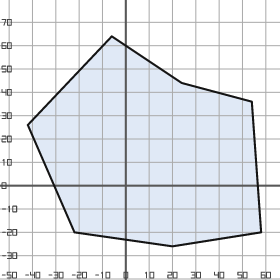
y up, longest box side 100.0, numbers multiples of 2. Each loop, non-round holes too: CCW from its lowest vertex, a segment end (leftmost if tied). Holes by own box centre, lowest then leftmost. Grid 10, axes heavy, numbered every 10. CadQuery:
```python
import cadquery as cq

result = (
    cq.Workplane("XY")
    .moveTo(20.0, -26.0)
    .lineTo(58.0, -20.0)
    .lineTo(54.0, 36.0)
    .lineTo(24.0, 44.0)
    .lineTo(-6.0, 64.0)
    .lineTo(-42.0, 26.0)
    .lineTo(-22.0, -20.0)
    .close()
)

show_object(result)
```